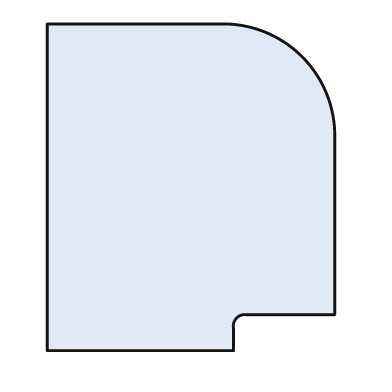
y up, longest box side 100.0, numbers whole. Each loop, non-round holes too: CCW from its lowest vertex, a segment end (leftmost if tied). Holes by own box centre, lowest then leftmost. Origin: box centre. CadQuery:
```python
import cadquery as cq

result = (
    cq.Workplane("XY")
    .moveTo(-44.0, -50.0)
    .lineTo(13.0, -50.0)
    .lineTo(13.0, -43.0)
    .threePointArc((14.0, -40.0), (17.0, -39.0))
    .lineTo(44.0, -39.0)
    .lineTo(44.0, 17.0)
    .threePointArc((34.0, 40.0), (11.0, 50.0))
    .lineTo(-44.0, 50.0)
    .close()
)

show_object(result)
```